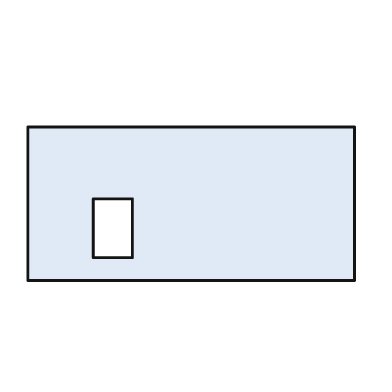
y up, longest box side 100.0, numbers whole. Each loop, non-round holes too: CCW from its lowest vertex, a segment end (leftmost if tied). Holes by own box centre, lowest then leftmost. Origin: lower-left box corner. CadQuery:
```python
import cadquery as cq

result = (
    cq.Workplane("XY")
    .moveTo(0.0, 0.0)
    .lineTo(100.0, 0.0)
    .lineTo(100.0, 47.0)
    .lineTo(0.0, 47.0)
    .close()
    .moveTo(20.0, 7.0)
    .lineTo(32.0, 7.0)
    .lineTo(32.0, 25.0)
    .lineTo(20.0, 25.0)
    .close()
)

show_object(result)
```